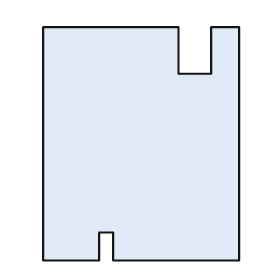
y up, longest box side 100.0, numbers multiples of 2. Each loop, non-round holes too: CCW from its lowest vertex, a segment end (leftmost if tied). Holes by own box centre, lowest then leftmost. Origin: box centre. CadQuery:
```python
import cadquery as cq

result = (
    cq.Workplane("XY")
    .moveTo(-42.0, -50.0)
    .lineTo(-18.0, -50.0)
    .lineTo(-18.0, -38.0)
    .lineTo(-12.0, -38.0)
    .lineTo(-12.0, -50.0)
    .lineTo(42.0, -50.0)
    .lineTo(42.0, 50.0)
    .lineTo(30.0, 50.0)
    .lineTo(30.0, 30.0)
    .lineTo(16.0, 30.0)
    .lineTo(16.0, 50.0)
    .lineTo(-42.0, 50.0)
    .close()
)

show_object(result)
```